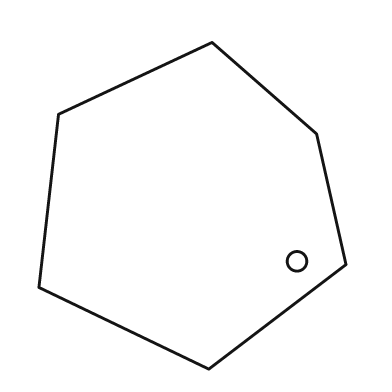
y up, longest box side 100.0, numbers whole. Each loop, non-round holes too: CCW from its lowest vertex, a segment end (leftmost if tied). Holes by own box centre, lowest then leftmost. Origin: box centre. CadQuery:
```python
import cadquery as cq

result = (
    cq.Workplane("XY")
    .moveTo(5.0, -50.0)
    .lineTo(47.0, -18.0)
    .lineTo(38.0, 22.0)
    .lineTo(6.0, 50.0)
    .lineTo(-41.0, 28.0)
    .lineTo(-47.0, -25.0)
    .close()
    .moveTo(32.0, -17.0)
    .circle(3.0)
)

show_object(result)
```